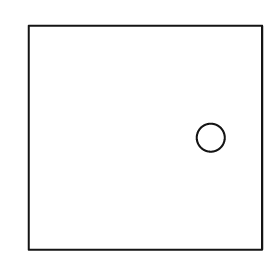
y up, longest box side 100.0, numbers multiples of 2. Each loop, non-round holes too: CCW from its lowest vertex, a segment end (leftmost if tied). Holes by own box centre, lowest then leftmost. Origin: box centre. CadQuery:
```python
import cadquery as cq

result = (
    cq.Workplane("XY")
    .moveTo(-50.0, -48.0)
    .lineTo(50.0, -48.0)
    .lineTo(50.0, 48.0)
    .lineTo(-50.0, 48.0)
    .close()
    .moveTo(28.0, 0.0)
    .circle(6.0)
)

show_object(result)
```